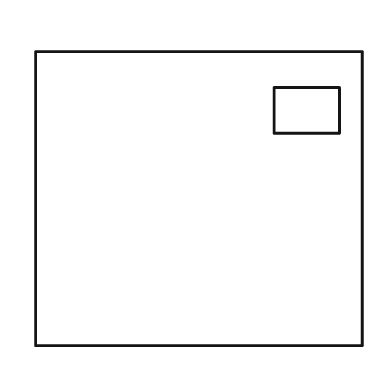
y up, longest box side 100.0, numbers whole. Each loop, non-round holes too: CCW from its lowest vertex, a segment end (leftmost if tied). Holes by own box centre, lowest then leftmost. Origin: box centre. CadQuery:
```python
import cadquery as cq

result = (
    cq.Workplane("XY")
    .moveTo(-50.0, -45.0)
    .lineTo(50.0, -45.0)
    .lineTo(50.0, 45.0)
    .lineTo(-50.0, 45.0)
    .close()
    .moveTo(23.0, 20.0)
    .lineTo(43.0, 20.0)
    .lineTo(43.0, 34.0)
    .lineTo(23.0, 34.0)
    .close()
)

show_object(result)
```